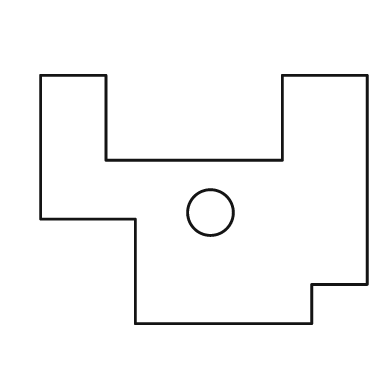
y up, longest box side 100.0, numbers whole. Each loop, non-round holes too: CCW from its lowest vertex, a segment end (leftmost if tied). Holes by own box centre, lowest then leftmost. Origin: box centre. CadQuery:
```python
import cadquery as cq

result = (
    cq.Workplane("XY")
    .moveTo(-21.0, -38.0)
    .lineTo(33.0, -38.0)
    .lineTo(33.0, -26.0)
    .lineTo(50.0, -26.0)
    .lineTo(50.0, 38.0)
    .lineTo(24.0, 38.0)
    .lineTo(24.0, 12.0)
    .lineTo(-30.0, 12.0)
    .lineTo(-30.0, 38.0)
    .lineTo(-50.0, 38.0)
    .lineTo(-50.0, -6.0)
    .lineTo(-21.0, -6.0)
    .close()
    .moveTo(2.0, -4.0)
    .circle(7.0)
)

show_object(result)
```